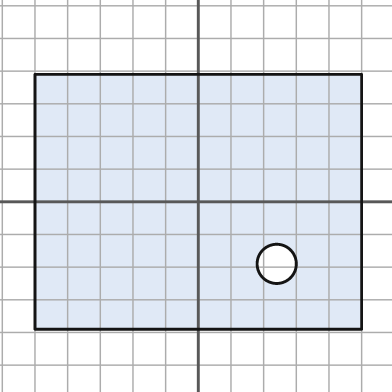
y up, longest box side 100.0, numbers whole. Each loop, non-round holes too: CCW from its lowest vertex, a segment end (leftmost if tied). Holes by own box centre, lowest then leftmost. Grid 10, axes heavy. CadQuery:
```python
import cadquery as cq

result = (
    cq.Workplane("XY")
    .moveTo(-50.0, -39.0)
    .lineTo(50.0, -39.0)
    .lineTo(50.0, 39.0)
    .lineTo(-50.0, 39.0)
    .close()
    .moveTo(24.0, -19.0)
    .circle(6.0)
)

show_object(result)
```